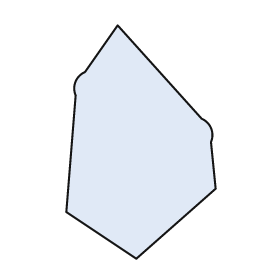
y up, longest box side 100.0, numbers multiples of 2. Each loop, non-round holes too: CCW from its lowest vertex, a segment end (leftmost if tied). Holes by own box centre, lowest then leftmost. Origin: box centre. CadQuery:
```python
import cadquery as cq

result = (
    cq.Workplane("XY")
    .moveTo(-2.0, -50.0)
    .lineTo(32.0, -20.0)
    .lineTo(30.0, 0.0)
    .threePointArc((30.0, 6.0), (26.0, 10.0))
    .lineTo(-10.0, 50.0)
    .lineTo(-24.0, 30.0)
    .threePointArc((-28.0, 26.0), (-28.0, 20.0))
    .lineTo(-32.0, -30.0)
    .close()
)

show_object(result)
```